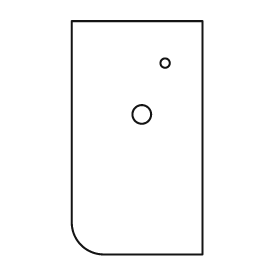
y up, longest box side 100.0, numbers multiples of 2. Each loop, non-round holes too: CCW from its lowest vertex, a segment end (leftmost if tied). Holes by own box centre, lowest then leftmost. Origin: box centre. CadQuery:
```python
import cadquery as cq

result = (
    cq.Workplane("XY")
    .moveTo(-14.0, -50.0)
    .lineTo(28.0, -50.0)
    .lineTo(28.0, 50.0)
    .lineTo(-28.0, 50.0)
    .lineTo(-28.0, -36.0)
    .threePointArc((-24.0, -46.0), (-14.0, -50.0))
    .close()
    .moveTo(2.0, 10.0)
    .circle(4.0)
    .moveTo(12.0, 32.0)
    .circle(2.0)
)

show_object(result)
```